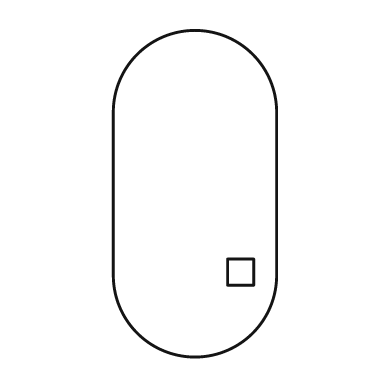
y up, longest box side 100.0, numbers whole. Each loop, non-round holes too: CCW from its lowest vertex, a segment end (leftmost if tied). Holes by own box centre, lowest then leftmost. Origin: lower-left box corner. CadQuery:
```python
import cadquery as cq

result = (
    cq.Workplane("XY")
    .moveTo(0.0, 25.0)
    .threePointArc((25.0, 0.0), (50.0, 25.0))
    .lineTo(50.0, 75.0)
    .threePointArc((25.0, 100.0), (0.0, 75.0))
    .close()
    .moveTo(35.0, 22.0)
    .lineTo(43.0, 22.0)
    .lineTo(43.0, 30.0)
    .lineTo(35.0, 30.0)
    .close()
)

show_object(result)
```